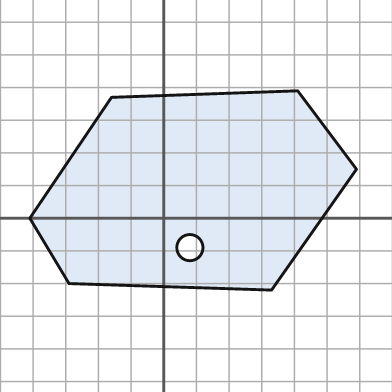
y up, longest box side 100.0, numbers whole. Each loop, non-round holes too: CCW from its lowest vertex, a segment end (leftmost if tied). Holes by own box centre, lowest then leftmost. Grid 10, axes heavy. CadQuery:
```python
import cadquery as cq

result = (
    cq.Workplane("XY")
    .moveTo(33.0, -22.0)
    .lineTo(59.0, 15.0)
    .lineTo(41.0, 39.0)
    .lineTo(-16.0, 37.0)
    .lineTo(-41.0, 0.0)
    .lineTo(-29.0, -20.0)
    .close()
    .moveTo(8.0, -9.0)
    .circle(4.0)
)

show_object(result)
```